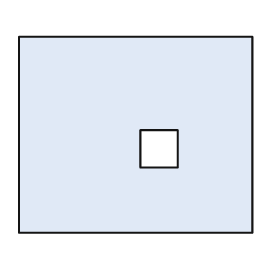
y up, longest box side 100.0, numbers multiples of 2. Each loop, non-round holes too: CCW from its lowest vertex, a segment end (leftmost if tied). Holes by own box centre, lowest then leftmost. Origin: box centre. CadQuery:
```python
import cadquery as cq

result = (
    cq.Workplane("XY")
    .moveTo(-50.0, -42.0)
    .lineTo(50.0, -42.0)
    .lineTo(50.0, 42.0)
    .lineTo(-50.0, 42.0)
    .close()
    .moveTo(2.0, -14.0)
    .lineTo(18.0, -14.0)
    .lineTo(18.0, 2.0)
    .lineTo(2.0, 2.0)
    .close()
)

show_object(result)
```